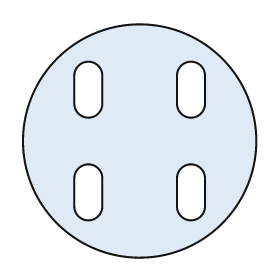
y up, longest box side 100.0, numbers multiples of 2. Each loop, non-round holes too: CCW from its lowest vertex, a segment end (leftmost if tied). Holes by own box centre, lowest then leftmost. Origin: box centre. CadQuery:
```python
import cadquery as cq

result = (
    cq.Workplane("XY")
    .moveTo(0.0, 0.0)
    .circle(50.0)
    .moveTo(-28.0, -28.0)
    .threePointArc((-22.0, -34.0), (-16.0, -28.0))
    .lineTo(-16.0, -16.0)
    .threePointArc((-22.0, -10.0), (-28.0, -16.0))
    .close()
    .moveTo(16.0, -28.0)
    .threePointArc((22.0, -34.0), (28.0, -28.0))
    .lineTo(28.0, -16.0)
    .threePointArc((22.0, -10.0), (16.0, -16.0))
    .close()
    .moveTo(-28.0, 16.0)
    .threePointArc((-22.0, 10.0), (-16.0, 16.0))
    .lineTo(-16.0, 28.0)
    .threePointArc((-22.0, 34.0), (-28.0, 28.0))
    .close()
    .moveTo(16.0, 16.0)
    .threePointArc((22.0, 10.0), (28.0, 16.0))
    .lineTo(28.0, 28.0)
    .threePointArc((22.0, 34.0), (16.0, 28.0))
    .close()
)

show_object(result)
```